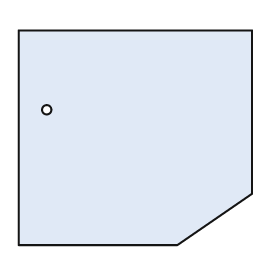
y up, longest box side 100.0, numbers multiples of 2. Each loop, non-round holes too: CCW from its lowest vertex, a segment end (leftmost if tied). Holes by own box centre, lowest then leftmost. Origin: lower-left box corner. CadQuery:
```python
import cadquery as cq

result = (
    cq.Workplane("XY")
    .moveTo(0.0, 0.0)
    .lineTo(68.0, 0.0)
    .lineTo(100.0, 22.0)
    .lineTo(100.0, 92.0)
    .lineTo(0.0, 92.0)
    .close()
    .moveTo(12.0, 58.0)
    .circle(2.0)
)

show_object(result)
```